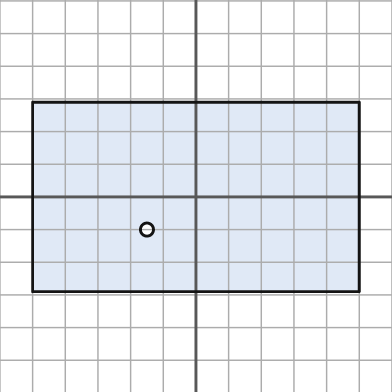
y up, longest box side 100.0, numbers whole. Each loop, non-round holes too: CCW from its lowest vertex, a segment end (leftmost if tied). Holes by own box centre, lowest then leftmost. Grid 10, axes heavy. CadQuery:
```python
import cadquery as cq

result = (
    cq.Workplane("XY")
    .moveTo(-50.0, -29.0)
    .lineTo(50.0, -29.0)
    .lineTo(50.0, 29.0)
    .lineTo(-50.0, 29.0)
    .close()
    .moveTo(-15.0, -10.0)
    .circle(2.0)
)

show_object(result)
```